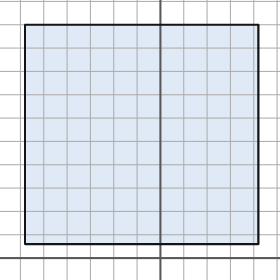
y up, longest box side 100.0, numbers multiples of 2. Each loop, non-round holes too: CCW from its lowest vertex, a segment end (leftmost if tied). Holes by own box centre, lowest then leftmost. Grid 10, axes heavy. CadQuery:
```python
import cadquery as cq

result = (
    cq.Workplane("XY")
    .moveTo(-58.0, 6.0)
    .lineTo(42.0, 6.0)
    .lineTo(42.0, 100.0)
    .lineTo(-58.0, 100.0)
    .close()
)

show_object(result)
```